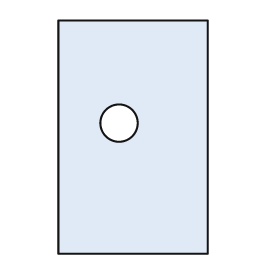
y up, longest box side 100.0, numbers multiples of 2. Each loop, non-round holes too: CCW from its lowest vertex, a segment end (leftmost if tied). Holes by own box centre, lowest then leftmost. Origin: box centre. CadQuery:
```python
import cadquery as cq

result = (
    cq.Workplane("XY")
    .moveTo(-32.0, -50.0)
    .lineTo(32.0, -50.0)
    .lineTo(32.0, 50.0)
    .lineTo(-32.0, 50.0)
    .close()
    .moveTo(-6.0, 6.0)
    .circle(8.0)
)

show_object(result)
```